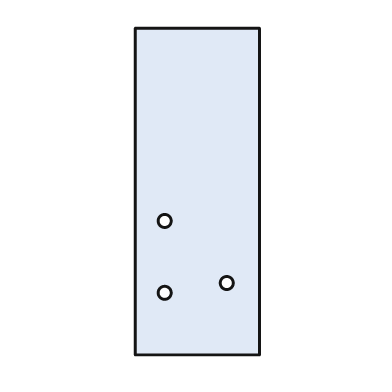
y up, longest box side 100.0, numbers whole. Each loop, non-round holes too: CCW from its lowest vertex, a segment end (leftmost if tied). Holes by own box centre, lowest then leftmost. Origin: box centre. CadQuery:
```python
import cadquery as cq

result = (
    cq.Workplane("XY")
    .moveTo(-19.0, -50.0)
    .lineTo(19.0, -50.0)
    .lineTo(19.0, 50.0)
    .lineTo(-19.0, 50.0)
    .close()
    .moveTo(-10.0, -31.0)
    .circle(2.0)
    .moveTo(9.0, -28.0)
    .circle(2.0)
    .moveTo(-10.0, -9.0)
    .circle(2.0)
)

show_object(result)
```